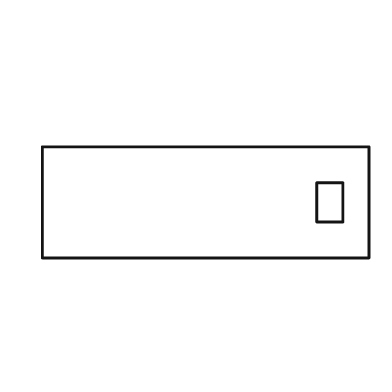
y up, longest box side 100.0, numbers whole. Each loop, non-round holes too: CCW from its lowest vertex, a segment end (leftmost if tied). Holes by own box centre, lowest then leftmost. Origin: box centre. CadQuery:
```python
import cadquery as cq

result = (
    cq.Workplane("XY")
    .moveTo(-50.0, -17.0)
    .lineTo(50.0, -17.0)
    .lineTo(50.0, 17.0)
    .lineTo(-50.0, 17.0)
    .close()
    .moveTo(34.0, -6.0)
    .lineTo(42.0, -6.0)
    .lineTo(42.0, 6.0)
    .lineTo(34.0, 6.0)
    .close()
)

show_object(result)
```